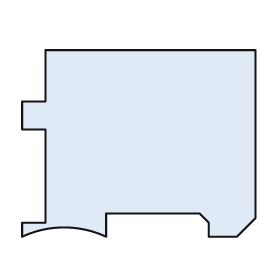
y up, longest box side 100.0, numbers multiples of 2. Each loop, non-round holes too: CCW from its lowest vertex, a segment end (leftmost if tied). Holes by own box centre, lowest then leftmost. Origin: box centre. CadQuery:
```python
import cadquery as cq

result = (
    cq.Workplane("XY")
    .moveTo(-50.0, -40.0)
    .threePointArc((-32.0, -36.0), (-14.0, -40.0))
    .lineTo(-14.0, -30.0)
    .lineTo(26.0, -30.0)
    .lineTo(30.0, -34.0)
    .lineTo(30.0, -40.0)
    .lineTo(42.0, -40.0)
    .lineTo(50.0, -32.0)
    .lineTo(50.0, 40.0)
    .lineTo(-40.0, 40.0)
    .lineTo(-40.0, 18.0)
    .lineTo(-50.0, 18.0)
    .lineTo(-50.0, 6.0)
    .lineTo(-40.0, 6.0)
    .lineTo(-40.0, -34.0)
    .lineTo(-50.0, -34.0)
    .close()
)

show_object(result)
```